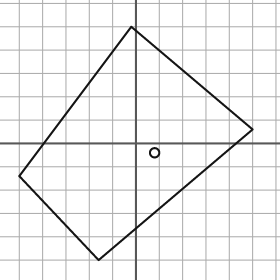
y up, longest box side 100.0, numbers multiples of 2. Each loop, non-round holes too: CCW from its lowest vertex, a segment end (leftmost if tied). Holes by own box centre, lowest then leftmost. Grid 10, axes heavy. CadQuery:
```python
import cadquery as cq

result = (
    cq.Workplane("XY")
    .moveTo(-16.0, -50.0)
    .lineTo(50.0, 6.0)
    .lineTo(-2.0, 50.0)
    .lineTo(-50.0, -14.0)
    .close()
    .moveTo(8.0, -4.0)
    .circle(2.0)
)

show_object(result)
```